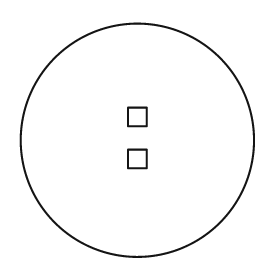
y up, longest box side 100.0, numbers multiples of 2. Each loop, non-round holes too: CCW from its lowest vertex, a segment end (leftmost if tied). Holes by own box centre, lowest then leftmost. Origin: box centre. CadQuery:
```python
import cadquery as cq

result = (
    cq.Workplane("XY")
    .moveTo(0.0, 0.0)
    .circle(50.0)
    .moveTo(-4.0, -12.0)
    .lineTo(4.0, -12.0)
    .lineTo(4.0, -4.0)
    .lineTo(-4.0, -4.0)
    .close()
    .moveTo(-4.0, 6.0)
    .lineTo(4.0, 6.0)
    .lineTo(4.0, 14.0)
    .lineTo(-4.0, 14.0)
    .close()
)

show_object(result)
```